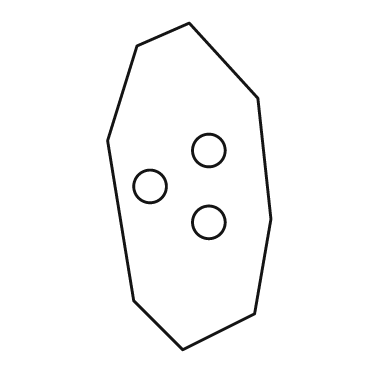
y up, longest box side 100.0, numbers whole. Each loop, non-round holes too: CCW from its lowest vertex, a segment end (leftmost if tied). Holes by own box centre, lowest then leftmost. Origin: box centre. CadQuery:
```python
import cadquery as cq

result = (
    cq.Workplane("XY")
    .moveTo(-2.0, -50.0)
    .lineTo(20.0, -39.0)
    .lineTo(25.0, -10.0)
    .lineTo(21.0, 27.0)
    .lineTo(0.0, 50.0)
    .lineTo(-16.0, 43.0)
    .lineTo(-25.0, 14.0)
    .lineTo(-17.0, -35.0)
    .close()
    .moveTo(6.0, -11.0)
    .circle(5.0)
    .moveTo(-12.0, 0.0)
    .circle(5.0)
    .moveTo(6.0, 11.0)
    .circle(5.0)
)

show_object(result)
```